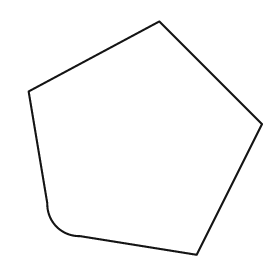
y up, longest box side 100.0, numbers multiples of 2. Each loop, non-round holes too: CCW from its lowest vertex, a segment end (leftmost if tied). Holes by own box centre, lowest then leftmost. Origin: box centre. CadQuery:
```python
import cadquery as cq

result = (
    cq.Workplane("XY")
    .moveTo(22.0, -50.0)
    .lineTo(50.0, 6.0)
    .lineTo(6.0, 50.0)
    .lineTo(-50.0, 20.0)
    .lineTo(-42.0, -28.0)
    .threePointArc((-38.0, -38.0), (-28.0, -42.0))
    .close()
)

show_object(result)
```